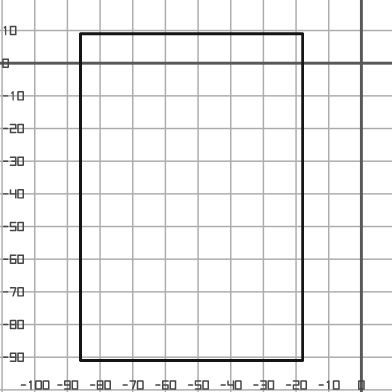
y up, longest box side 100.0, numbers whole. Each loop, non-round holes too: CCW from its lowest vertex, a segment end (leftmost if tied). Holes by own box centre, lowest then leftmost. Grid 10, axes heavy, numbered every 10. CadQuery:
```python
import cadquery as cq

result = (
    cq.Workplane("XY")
    .moveTo(-86.0, -91.0)
    .lineTo(-18.0, -91.0)
    .lineTo(-18.0, 9.0)
    .lineTo(-86.0, 9.0)
    .close()
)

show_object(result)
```